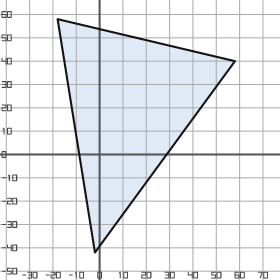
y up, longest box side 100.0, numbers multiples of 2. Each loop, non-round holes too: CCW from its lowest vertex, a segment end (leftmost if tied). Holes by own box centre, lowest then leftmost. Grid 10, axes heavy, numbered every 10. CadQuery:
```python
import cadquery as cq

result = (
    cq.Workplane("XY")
    .moveTo(-2.0, -42.0)
    .lineTo(58.0, 40.0)
    .lineTo(-18.0, 58.0)
    .close()
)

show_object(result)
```